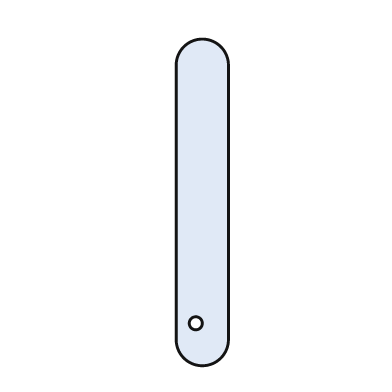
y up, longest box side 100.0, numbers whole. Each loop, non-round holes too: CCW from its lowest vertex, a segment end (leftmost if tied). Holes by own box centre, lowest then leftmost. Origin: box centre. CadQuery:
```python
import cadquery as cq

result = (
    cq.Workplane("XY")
    .moveTo(-8.0, -42.0)
    .threePointArc((0.0, -50.0), (8.0, -42.0))
    .lineTo(8.0, 42.0)
    .threePointArc((0.0, 50.0), (-8.0, 42.0))
    .close()
    .moveTo(-2.0, -37.0)
    .circle(2.0)
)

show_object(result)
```